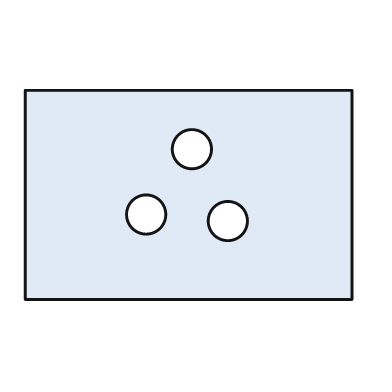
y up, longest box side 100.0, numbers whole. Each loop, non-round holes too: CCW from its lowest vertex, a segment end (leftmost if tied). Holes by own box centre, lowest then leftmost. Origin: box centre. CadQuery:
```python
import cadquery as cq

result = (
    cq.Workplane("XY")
    .moveTo(-50.0, -32.0)
    .lineTo(50.0, -32.0)
    .lineTo(50.0, 32.0)
    .lineTo(-50.0, 32.0)
    .close()
    .moveTo(12.0, -8.0)
    .circle(6.0)
    .moveTo(-13.0, -6.0)
    .circle(6.0)
    .moveTo(1.0, 14.0)
    .circle(6.0)
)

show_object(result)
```